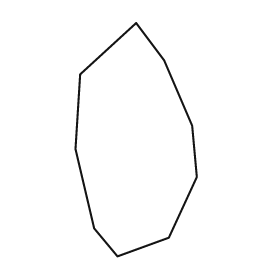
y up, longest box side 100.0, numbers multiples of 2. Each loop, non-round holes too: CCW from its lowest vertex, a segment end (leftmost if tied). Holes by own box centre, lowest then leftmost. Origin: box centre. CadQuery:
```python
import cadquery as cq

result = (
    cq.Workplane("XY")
    .moveTo(-8.0, -50.0)
    .lineTo(14.0, -42.0)
    .lineTo(26.0, -16.0)
    .lineTo(24.0, 6.0)
    .lineTo(12.0, 34.0)
    .lineTo(0.0, 50.0)
    .lineTo(-24.0, 28.0)
    .lineTo(-26.0, -4.0)
    .lineTo(-18.0, -38.0)
    .close()
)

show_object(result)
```